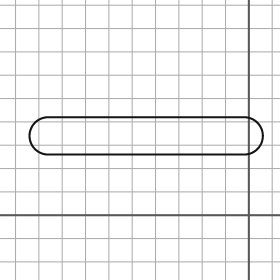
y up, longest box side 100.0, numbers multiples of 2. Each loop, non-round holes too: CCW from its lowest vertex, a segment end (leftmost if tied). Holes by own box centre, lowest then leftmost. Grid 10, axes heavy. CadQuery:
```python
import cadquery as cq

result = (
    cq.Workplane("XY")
    .moveTo(-86.0, 26.0)
    .lineTo(-2.0, 26.0)
    .threePointArc((6.0, 34.0), (-2.0, 42.0))
    .lineTo(-86.0, 42.0)
    .threePointArc((-94.0, 34.0), (-86.0, 26.0))
    .close()
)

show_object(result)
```